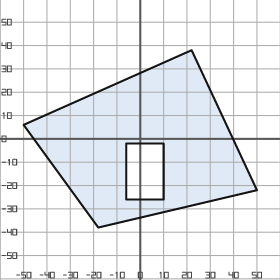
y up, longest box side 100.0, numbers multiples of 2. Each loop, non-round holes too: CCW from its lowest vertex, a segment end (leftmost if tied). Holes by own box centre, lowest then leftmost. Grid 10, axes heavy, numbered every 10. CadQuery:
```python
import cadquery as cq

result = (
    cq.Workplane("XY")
    .moveTo(-18.0, -38.0)
    .lineTo(50.0, -22.0)
    .lineTo(22.0, 38.0)
    .lineTo(-50.0, 6.0)
    .close()
    .moveTo(-6.0, -26.0)
    .lineTo(10.0, -26.0)
    .lineTo(10.0, -2.0)
    .lineTo(-6.0, -2.0)
    .close()
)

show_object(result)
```